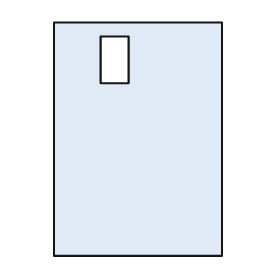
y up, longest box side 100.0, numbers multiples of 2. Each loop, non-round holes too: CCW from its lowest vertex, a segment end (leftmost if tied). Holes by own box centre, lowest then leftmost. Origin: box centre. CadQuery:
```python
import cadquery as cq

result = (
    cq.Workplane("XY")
    .moveTo(-36.0, -50.0)
    .lineTo(36.0, -50.0)
    .lineTo(36.0, 50.0)
    .lineTo(-36.0, 50.0)
    .close()
    .moveTo(-16.0, 24.0)
    .lineTo(-4.0, 24.0)
    .lineTo(-4.0, 44.0)
    .lineTo(-16.0, 44.0)
    .close()
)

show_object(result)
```